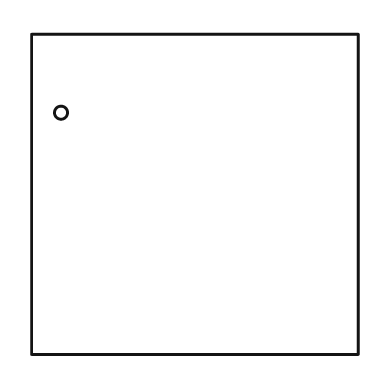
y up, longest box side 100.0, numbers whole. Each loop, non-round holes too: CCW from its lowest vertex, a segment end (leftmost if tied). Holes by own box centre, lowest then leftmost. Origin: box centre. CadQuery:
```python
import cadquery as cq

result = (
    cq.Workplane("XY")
    .moveTo(-50.0, -49.0)
    .lineTo(50.0, -49.0)
    .lineTo(50.0, 49.0)
    .lineTo(-50.0, 49.0)
    .close()
    .moveTo(-41.0, 25.0)
    .circle(2.0)
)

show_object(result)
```